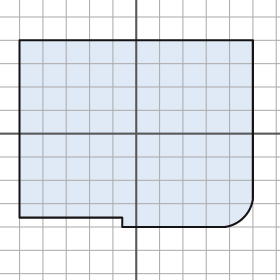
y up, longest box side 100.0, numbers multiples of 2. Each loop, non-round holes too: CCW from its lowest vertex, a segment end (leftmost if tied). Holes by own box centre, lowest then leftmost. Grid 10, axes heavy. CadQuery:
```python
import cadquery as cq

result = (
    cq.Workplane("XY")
    .moveTo(-6.0, -40.0)
    .lineTo(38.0, -40.0)
    .threePointArc((46.0, -36.0), (50.0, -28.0))
    .lineTo(50.0, 40.0)
    .lineTo(-50.0, 40.0)
    .lineTo(-50.0, -36.0)
    .lineTo(-6.0, -36.0)
    .close()
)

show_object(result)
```